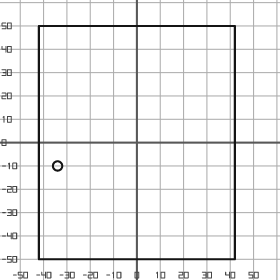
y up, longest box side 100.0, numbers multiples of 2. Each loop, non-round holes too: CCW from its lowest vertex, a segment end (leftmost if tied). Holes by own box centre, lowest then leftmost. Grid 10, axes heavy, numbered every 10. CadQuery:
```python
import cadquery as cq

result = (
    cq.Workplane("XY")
    .moveTo(-42.0, -50.0)
    .lineTo(42.0, -50.0)
    .lineTo(42.0, 50.0)
    .lineTo(-42.0, 50.0)
    .close()
    .moveTo(-34.0, -10.0)
    .circle(2.0)
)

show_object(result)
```